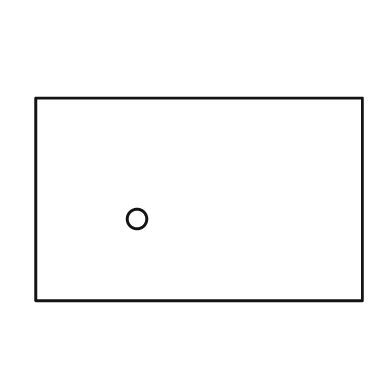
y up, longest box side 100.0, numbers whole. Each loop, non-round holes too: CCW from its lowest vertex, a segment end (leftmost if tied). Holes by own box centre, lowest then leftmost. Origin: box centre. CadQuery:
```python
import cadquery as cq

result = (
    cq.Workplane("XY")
    .moveTo(-50.0, -31.0)
    .lineTo(50.0, -31.0)
    .lineTo(50.0, 31.0)
    .lineTo(-50.0, 31.0)
    .close()
    .moveTo(-19.0, -6.0)
    .circle(3.0)
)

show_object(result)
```